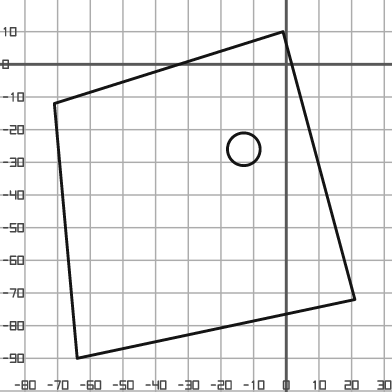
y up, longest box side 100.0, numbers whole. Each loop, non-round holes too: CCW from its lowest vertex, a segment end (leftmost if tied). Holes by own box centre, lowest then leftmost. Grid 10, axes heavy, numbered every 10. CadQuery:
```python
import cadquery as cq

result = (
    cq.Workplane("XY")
    .moveTo(-64.0, -90.0)
    .lineTo(21.0, -72.0)
    .lineTo(-1.0, 10.0)
    .lineTo(-71.0, -12.0)
    .close()
    .moveTo(-13.0, -26.0)
    .circle(5.0)
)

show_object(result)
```